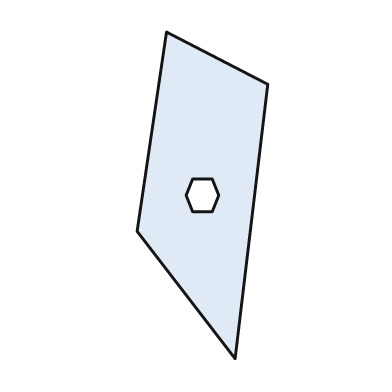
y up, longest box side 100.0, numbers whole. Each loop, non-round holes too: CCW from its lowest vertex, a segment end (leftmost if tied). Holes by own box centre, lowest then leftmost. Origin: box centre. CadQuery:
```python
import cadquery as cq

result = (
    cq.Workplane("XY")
    .moveTo(10.0, -50.0)
    .lineTo(20.0, 34.0)
    .lineTo(-11.0, 50.0)
    .lineTo(-20.0, -11.0)
    .close()
    .moveTo(-3.0, -5.0)
    .lineTo(3.0, -5.0)
    .lineTo(5.0, 0.0)
    .lineTo(3.0, 5.0)
    .lineTo(-3.0, 5.0)
    .lineTo(-5.0, 0.0)
    .close()
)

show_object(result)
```